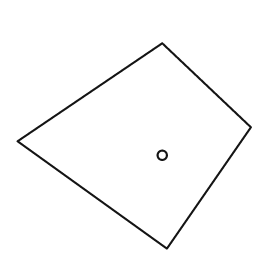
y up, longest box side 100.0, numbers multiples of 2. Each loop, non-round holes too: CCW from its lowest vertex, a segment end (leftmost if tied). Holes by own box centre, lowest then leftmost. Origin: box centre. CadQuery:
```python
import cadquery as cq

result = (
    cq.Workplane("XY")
    .moveTo(14.0, -44.0)
    .lineTo(50.0, 8.0)
    .lineTo(12.0, 44.0)
    .lineTo(-50.0, 2.0)
    .close()
    .moveTo(12.0, -4.0)
    .circle(2.0)
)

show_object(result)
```